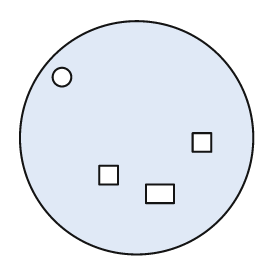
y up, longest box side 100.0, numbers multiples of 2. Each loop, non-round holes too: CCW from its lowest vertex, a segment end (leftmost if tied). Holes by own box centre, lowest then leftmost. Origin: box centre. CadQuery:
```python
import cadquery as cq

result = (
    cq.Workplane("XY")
    .moveTo(0.0, 0.0)
    .circle(50.0)
    .moveTo(4.0, -28.0)
    .lineTo(16.0, -28.0)
    .lineTo(16.0, -20.0)
    .lineTo(4.0, -20.0)
    .close()
    .moveTo(-16.0, -20.0)
    .lineTo(-8.0, -20.0)
    .lineTo(-8.0, -12.0)
    .lineTo(-16.0, -12.0)
    .close()
    .moveTo(24.0, -6.0)
    .lineTo(32.0, -6.0)
    .lineTo(32.0, 2.0)
    .lineTo(24.0, 2.0)
    .close()
    .moveTo(-32.0, 26.0)
    .circle(4.0)
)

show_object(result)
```